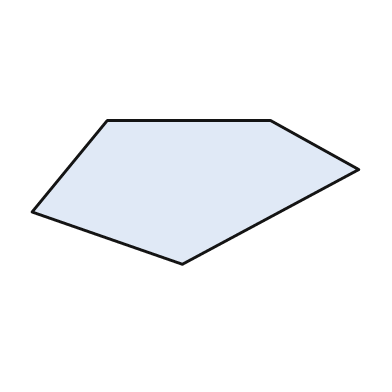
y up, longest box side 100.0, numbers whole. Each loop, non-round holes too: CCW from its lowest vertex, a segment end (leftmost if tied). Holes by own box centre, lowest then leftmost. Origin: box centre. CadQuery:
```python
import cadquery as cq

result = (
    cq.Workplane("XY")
    .moveTo(-4.0, -22.0)
    .lineTo(50.0, 7.0)
    .lineTo(23.0, 22.0)
    .lineTo(-27.0, 22.0)
    .lineTo(-50.0, -6.0)
    .close()
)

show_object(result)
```